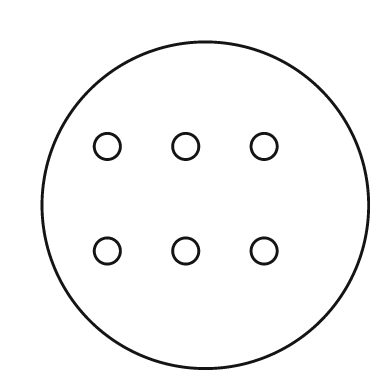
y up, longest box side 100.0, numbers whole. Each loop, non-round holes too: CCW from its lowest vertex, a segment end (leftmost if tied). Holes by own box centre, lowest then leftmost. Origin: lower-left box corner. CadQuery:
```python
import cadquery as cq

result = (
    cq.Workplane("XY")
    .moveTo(50.0, 50.0)
    .circle(50.0)
    .moveTo(20.0, 36.0)
    .circle(4.0)
    .moveTo(44.0, 36.0)
    .circle(4.0)
    .moveTo(68.0, 36.0)
    .circle(4.0)
    .moveTo(20.0, 68.0)
    .circle(4.0)
    .moveTo(44.0, 68.0)
    .circle(4.0)
    .moveTo(68.0, 68.0)
    .circle(4.0)
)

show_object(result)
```